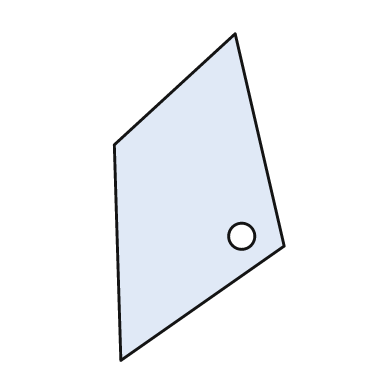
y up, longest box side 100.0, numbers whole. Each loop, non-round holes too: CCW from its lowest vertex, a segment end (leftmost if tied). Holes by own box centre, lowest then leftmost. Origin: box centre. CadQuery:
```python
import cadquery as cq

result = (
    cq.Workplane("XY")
    .moveTo(-24.0, -50.0)
    .lineTo(26.0, -15.0)
    .lineTo(11.0, 50.0)
    .lineTo(-26.0, 16.0)
    .close()
    .moveTo(13.0, -12.0)
    .circle(4.0)
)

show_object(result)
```